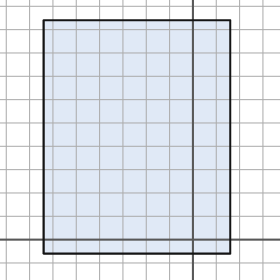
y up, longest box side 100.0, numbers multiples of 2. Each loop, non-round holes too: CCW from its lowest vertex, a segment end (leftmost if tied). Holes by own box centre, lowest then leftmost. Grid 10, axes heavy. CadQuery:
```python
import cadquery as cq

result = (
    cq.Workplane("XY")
    .moveTo(-64.0, -6.0)
    .lineTo(16.0, -6.0)
    .lineTo(16.0, 94.0)
    .lineTo(-64.0, 94.0)
    .close()
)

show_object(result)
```